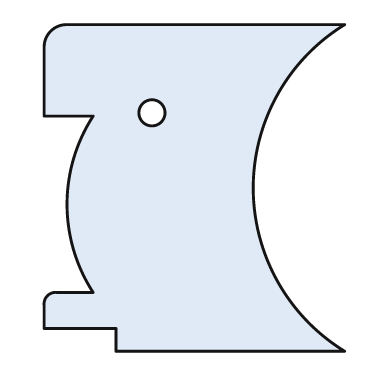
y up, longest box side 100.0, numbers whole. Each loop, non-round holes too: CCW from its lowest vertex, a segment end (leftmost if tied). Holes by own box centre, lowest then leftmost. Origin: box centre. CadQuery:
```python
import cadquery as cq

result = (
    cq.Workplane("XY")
    .moveTo(-24.0, -50.0)
    .lineTo(46.0, -50.0)
    .threePointArc((18.0, 0.0), (46.0, 50.0))
    .lineTo(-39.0, 50.0)
    .threePointArc((-44.0, 48.0), (-46.0, 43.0))
    .lineTo(-46.0, 22.0)
    .lineTo(-31.0, 22.0)
    .threePointArc((-39.0, -5.0), (-31.0, -32.0))
    .lineTo(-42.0, -32.0)
    .threePointArc((-45.0, -33.0), (-46.0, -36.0))
    .lineTo(-46.0, -43.0)
    .lineTo(-24.0, -43.0)
    .close()
    .moveTo(-13.0, 23.0)
    .circle(4.0)
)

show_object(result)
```